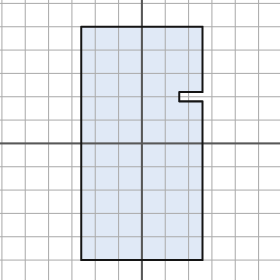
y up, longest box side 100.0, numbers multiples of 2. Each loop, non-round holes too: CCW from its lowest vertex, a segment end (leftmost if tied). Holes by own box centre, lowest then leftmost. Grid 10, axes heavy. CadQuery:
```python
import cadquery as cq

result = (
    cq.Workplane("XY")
    .moveTo(-26.0, -50.0)
    .lineTo(26.0, -50.0)
    .lineTo(26.0, 18.0)
    .lineTo(16.0, 18.0)
    .lineTo(16.0, 22.0)
    .lineTo(26.0, 22.0)
    .lineTo(26.0, 50.0)
    .lineTo(-26.0, 50.0)
    .close()
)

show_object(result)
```